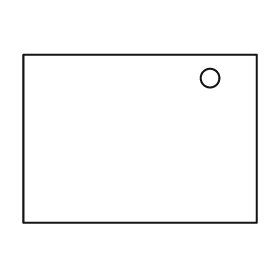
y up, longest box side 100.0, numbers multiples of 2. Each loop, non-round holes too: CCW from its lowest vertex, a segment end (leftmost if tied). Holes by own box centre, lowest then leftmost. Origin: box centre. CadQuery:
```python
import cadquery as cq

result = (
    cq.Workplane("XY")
    .moveTo(-50.0, -36.0)
    .lineTo(50.0, -36.0)
    .lineTo(50.0, 36.0)
    .lineTo(-50.0, 36.0)
    .close()
    .moveTo(30.0, 26.0)
    .circle(4.0)
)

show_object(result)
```